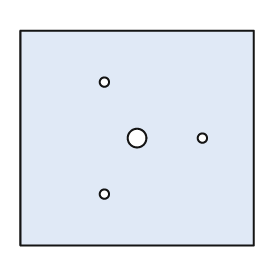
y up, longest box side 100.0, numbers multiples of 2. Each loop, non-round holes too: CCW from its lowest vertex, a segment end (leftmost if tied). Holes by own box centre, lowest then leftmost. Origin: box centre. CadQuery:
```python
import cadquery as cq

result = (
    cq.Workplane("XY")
    .moveTo(-50.0, -46.0)
    .lineTo(50.0, -46.0)
    .lineTo(50.0, 46.0)
    .lineTo(-50.0, 46.0)
    .close()
    .moveTo(-14.0, -24.0)
    .circle(2.0)
    .moveTo(0.0, 0.0)
    .circle(4.0)
    .moveTo(28.0, 0.0)
    .circle(2.0)
    .moveTo(-14.0, 24.0)
    .circle(2.0)
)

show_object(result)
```